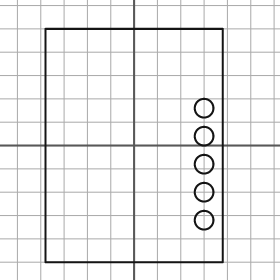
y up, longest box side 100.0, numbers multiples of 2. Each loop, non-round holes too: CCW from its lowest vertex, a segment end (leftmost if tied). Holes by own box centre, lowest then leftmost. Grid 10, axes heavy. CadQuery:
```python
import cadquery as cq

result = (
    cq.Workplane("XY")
    .moveTo(-38.0, -50.0)
    .lineTo(38.0, -50.0)
    .lineTo(38.0, 50.0)
    .lineTo(-38.0, 50.0)
    .close()
    .moveTo(30.0, -32.0)
    .circle(4.0)
    .moveTo(30.0, -20.0)
    .circle(4.0)
    .moveTo(30.0, -8.0)
    .circle(4.0)
    .moveTo(30.0, 4.0)
    .circle(4.0)
    .moveTo(30.0, 16.0)
    .circle(4.0)
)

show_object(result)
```